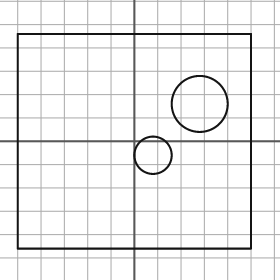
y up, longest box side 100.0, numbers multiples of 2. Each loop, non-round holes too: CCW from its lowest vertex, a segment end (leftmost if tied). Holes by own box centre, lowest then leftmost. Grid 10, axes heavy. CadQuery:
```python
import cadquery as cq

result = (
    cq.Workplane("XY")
    .moveTo(-50.0, -46.0)
    .lineTo(50.0, -46.0)
    .lineTo(50.0, 46.0)
    .lineTo(-50.0, 46.0)
    .close()
    .moveTo(8.0, -6.0)
    .circle(8.0)
    .moveTo(28.0, 16.0)
    .circle(12.0)
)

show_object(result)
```